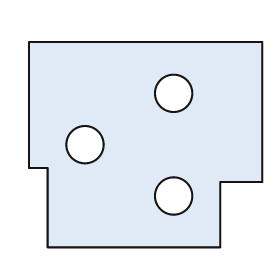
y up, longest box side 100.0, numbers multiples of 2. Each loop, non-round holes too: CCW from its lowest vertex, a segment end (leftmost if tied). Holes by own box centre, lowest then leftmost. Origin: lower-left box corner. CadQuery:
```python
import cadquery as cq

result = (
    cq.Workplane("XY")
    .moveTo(8.0, 0.0)
    .lineTo(82.0, 0.0)
    .lineTo(82.0, 28.0)
    .lineTo(100.0, 28.0)
    .lineTo(100.0, 88.0)
    .lineTo(0.0, 88.0)
    .lineTo(0.0, 34.0)
    .lineTo(8.0, 34.0)
    .close()
    .moveTo(62.0, 22.0)
    .circle(8.0)
    .moveTo(24.0, 44.0)
    .circle(8.0)
    .moveTo(62.0, 66.0)
    .circle(8.0)
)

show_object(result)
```